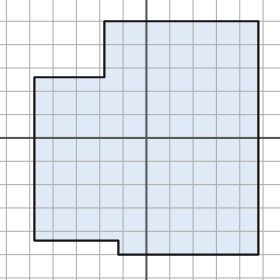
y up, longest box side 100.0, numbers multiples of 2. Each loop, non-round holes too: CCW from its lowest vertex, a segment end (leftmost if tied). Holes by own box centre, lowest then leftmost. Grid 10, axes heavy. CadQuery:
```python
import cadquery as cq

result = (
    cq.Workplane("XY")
    .moveTo(-12.0, -50.0)
    .lineTo(48.0, -50.0)
    .lineTo(48.0, 50.0)
    .lineTo(-18.0, 50.0)
    .lineTo(-18.0, 26.0)
    .lineTo(-48.0, 26.0)
    .lineTo(-48.0, -44.0)
    .lineTo(-12.0, -44.0)
    .close()
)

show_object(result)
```